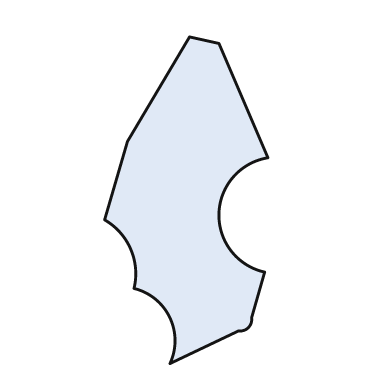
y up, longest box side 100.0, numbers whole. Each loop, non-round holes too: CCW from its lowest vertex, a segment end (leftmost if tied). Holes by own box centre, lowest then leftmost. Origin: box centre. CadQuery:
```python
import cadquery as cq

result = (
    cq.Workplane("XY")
    .moveTo(-5.0, -50.0)
    .lineTo(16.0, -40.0)
    .threePointArc((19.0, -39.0), (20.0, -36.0))
    .lineTo(24.0, -22.0)
    .threePointArc((10.0, -4.0), (25.0, 13.0))
    .lineTo(10.0, 48.0)
    .lineTo(1.0, 50.0)
    .lineTo(-18.0, 18.0)
    .lineTo(-25.0, -6.0)
    .threePointArc((-17.0, -15.0), (-16.0, -27.0))
    .threePointArc((-5.0, -36.0), (-5.0, -50.0))
    .close()
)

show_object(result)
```